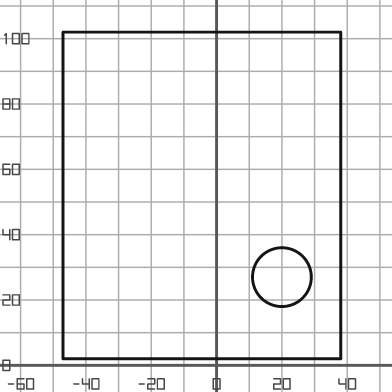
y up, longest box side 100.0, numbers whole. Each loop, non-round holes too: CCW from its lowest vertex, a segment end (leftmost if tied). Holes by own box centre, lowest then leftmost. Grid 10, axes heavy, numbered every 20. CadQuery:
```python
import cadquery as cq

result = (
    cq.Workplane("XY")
    .moveTo(-47.0, 2.0)
    .lineTo(38.0, 2.0)
    .lineTo(38.0, 102.0)
    .lineTo(-47.0, 102.0)
    .close()
    .moveTo(20.0, 27.0)
    .circle(9.0)
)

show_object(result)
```